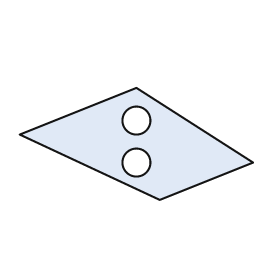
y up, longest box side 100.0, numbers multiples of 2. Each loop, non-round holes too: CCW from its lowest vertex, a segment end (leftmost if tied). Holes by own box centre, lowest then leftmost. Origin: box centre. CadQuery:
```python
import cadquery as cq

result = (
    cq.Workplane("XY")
    .moveTo(10.0, -24.0)
    .lineTo(50.0, -8.0)
    .lineTo(0.0, 24.0)
    .lineTo(-50.0, 4.0)
    .close()
    .moveTo(0.0, -8.0)
    .circle(6.0)
    .moveTo(0.0, 10.0)
    .circle(6.0)
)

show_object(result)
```